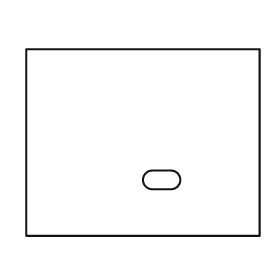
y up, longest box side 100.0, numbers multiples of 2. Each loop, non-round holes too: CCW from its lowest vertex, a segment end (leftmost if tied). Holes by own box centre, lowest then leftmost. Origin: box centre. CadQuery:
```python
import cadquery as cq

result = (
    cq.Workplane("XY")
    .moveTo(-50.0, -40.0)
    .lineTo(50.0, -40.0)
    .lineTo(50.0, 40.0)
    .lineTo(-50.0, 40.0)
    .close()
    .moveTo(4.0, -20.0)
    .lineTo(12.0, -20.0)
    .threePointArc((16.0, -16.0), (12.0, -12.0))
    .lineTo(4.0, -12.0)
    .threePointArc((0.0, -16.0), (4.0, -20.0))
    .close()
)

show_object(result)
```